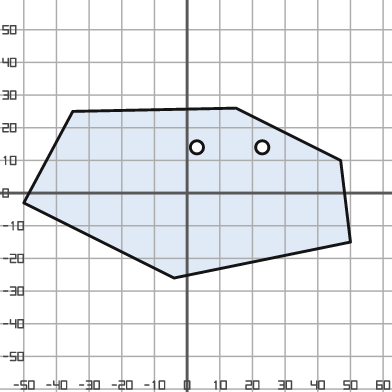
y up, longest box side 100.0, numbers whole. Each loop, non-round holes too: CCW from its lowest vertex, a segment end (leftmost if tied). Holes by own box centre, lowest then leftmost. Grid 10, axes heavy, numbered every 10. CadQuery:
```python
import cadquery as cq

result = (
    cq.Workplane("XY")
    .moveTo(-4.0, -26.0)
    .lineTo(50.0, -15.0)
    .lineTo(47.0, 10.0)
    .lineTo(15.0, 26.0)
    .lineTo(-35.0, 25.0)
    .lineTo(-50.0, -3.0)
    .close()
    .moveTo(3.0, 14.0)
    .circle(2.0)
    .moveTo(23.0, 14.0)
    .circle(2.0)
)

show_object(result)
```